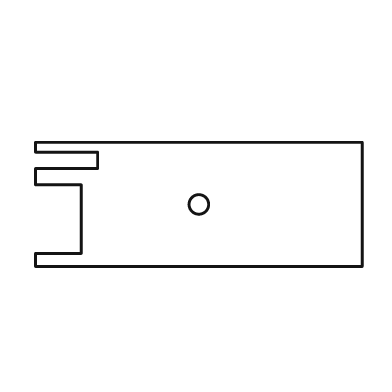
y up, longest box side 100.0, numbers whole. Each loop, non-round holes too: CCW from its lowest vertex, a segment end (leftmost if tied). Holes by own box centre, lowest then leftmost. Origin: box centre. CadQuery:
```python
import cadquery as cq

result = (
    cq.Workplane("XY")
    .moveTo(-50.0, -19.0)
    .lineTo(50.0, -19.0)
    .lineTo(50.0, 19.0)
    .lineTo(-50.0, 19.0)
    .lineTo(-50.0, 16.0)
    .lineTo(-31.0, 16.0)
    .lineTo(-31.0, 11.0)
    .lineTo(-50.0, 11.0)
    .lineTo(-50.0, 6.0)
    .lineTo(-36.0, 6.0)
    .lineTo(-36.0, -15.0)
    .lineTo(-50.0, -15.0)
    .close()
    .moveTo(0.0, 0.0)
    .circle(3.0)
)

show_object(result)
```